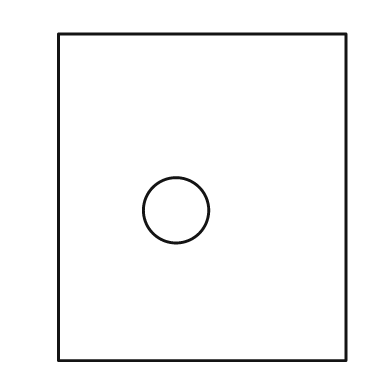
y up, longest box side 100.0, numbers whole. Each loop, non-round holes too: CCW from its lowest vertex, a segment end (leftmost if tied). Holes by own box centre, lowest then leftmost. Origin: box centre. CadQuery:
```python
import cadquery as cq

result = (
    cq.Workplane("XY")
    .moveTo(-44.0, -50.0)
    .lineTo(44.0, -50.0)
    .lineTo(44.0, 50.0)
    .lineTo(-44.0, 50.0)
    .close()
    .moveTo(-8.0, -4.0)
    .circle(10.0)
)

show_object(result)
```